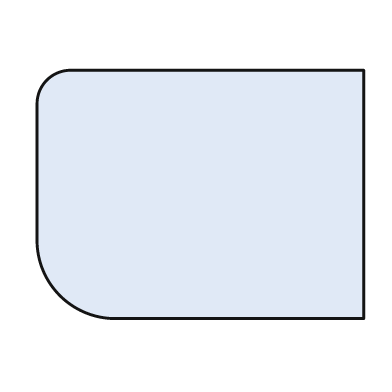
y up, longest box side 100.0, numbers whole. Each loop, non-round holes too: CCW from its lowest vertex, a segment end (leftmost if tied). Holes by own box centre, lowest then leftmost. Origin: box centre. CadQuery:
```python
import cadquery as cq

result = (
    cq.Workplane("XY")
    .moveTo(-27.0, -38.0)
    .lineTo(50.0, -38.0)
    .lineTo(50.0, 38.0)
    .lineTo(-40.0, 38.0)
    .threePointArc((-47.0, 35.0), (-50.0, 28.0))
    .lineTo(-50.0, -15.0)
    .threePointArc((-43.0, -31.0), (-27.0, -38.0))
    .close()
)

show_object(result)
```